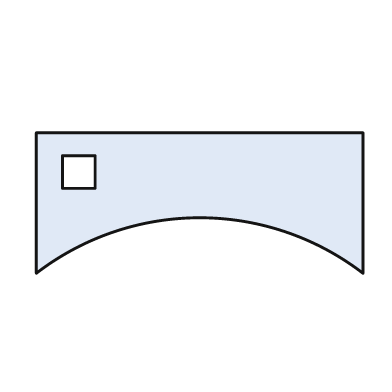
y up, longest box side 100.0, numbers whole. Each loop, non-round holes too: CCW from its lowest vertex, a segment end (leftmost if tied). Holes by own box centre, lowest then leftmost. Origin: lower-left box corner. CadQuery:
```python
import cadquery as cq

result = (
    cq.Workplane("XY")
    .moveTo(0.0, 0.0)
    .threePointArc((50.0, 17.0), (100.0, 0.0))
    .lineTo(100.0, 43.0)
    .lineTo(0.0, 43.0)
    .close()
    .moveTo(8.0, 26.0)
    .lineTo(18.0, 26.0)
    .lineTo(18.0, 36.0)
    .lineTo(8.0, 36.0)
    .close()
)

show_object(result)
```